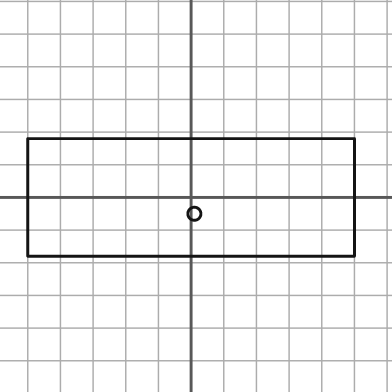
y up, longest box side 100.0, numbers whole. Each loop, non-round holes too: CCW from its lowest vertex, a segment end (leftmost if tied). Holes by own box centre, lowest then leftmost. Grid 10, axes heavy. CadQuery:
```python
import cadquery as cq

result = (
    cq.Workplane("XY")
    .moveTo(-50.0, -18.0)
    .lineTo(50.0, -18.0)
    .lineTo(50.0, 18.0)
    .lineTo(-50.0, 18.0)
    .close()
    .moveTo(1.0, -5.0)
    .circle(2.0)
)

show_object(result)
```